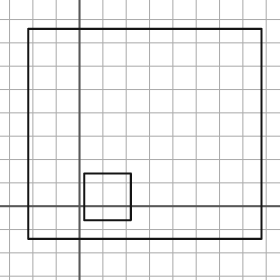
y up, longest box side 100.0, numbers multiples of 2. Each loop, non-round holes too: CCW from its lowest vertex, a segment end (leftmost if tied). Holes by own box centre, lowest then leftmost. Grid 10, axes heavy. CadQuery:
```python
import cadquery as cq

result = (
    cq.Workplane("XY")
    .moveTo(-22.0, -14.0)
    .lineTo(78.0, -14.0)
    .lineTo(78.0, 76.0)
    .lineTo(-22.0, 76.0)
    .close()
    .moveTo(2.0, -6.0)
    .lineTo(22.0, -6.0)
    .lineTo(22.0, 14.0)
    .lineTo(2.0, 14.0)
    .close()
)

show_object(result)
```